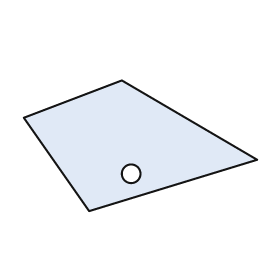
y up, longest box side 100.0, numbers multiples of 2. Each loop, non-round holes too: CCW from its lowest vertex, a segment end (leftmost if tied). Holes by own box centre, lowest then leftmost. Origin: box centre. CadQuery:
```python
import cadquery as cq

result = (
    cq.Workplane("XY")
    .moveTo(-22.0, -28.0)
    .lineTo(50.0, -6.0)
    .lineTo(-8.0, 28.0)
    .lineTo(-50.0, 12.0)
    .close()
    .moveTo(-4.0, -12.0)
    .circle(4.0)
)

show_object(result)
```